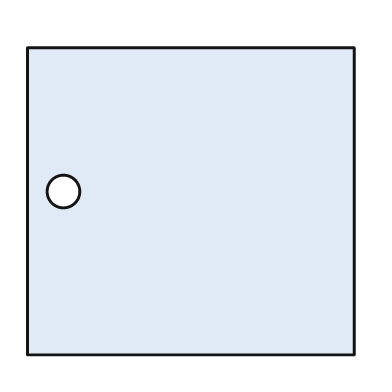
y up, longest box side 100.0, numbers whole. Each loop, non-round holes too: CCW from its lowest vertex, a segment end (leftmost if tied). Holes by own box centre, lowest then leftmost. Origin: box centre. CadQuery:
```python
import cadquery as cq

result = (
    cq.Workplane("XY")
    .moveTo(-50.0, -47.0)
    .lineTo(50.0, -47.0)
    .lineTo(50.0, 47.0)
    .lineTo(-50.0, 47.0)
    .close()
    .moveTo(-39.0, 3.0)
    .circle(5.0)
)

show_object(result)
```